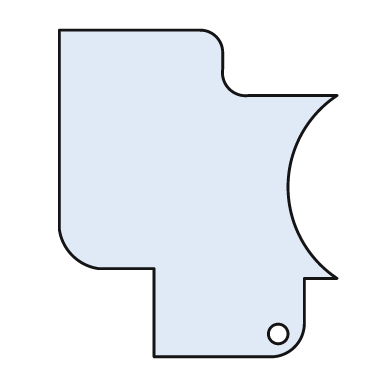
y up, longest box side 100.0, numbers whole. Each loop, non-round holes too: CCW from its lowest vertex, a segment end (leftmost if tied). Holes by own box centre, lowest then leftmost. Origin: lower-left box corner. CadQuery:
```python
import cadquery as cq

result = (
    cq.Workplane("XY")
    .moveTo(29.0, 0.0)
    .lineTo(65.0, 0.0)
    .threePointArc((72.0, 3.0), (75.0, 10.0))
    .lineTo(75.0, 24.0)
    .lineTo(85.0, 24.0)
    .threePointArc((70.0, 52.0), (85.0, 80.0))
    .lineTo(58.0, 80.0)
    .threePointArc((52.0, 82.0), (50.0, 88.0))
    .lineTo(50.0, 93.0)
    .threePointArc((48.0, 98.0), (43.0, 100.0))
    .lineTo(0.0, 100.0)
    .lineTo(0.0, 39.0)
    .threePointArc((4.0, 31.0), (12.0, 27.0))
    .lineTo(29.0, 27.0)
    .close()
    .moveTo(67.0, 7.0)
    .circle(3.0)
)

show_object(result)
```